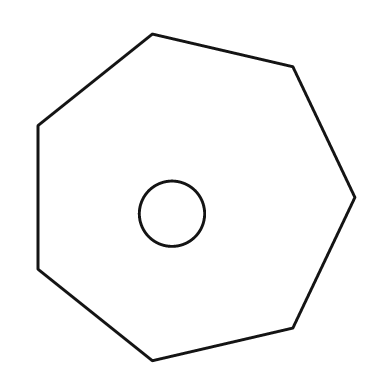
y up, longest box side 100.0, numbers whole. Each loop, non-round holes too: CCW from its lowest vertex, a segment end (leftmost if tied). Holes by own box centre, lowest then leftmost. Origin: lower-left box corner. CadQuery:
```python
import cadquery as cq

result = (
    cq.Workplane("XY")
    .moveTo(35.0, 0.0)
    .lineTo(78.0, 10.0)
    .lineTo(97.0, 50.0)
    .lineTo(78.0, 90.0)
    .lineTo(35.0, 100.0)
    .lineTo(0.0, 72.0)
    .lineTo(0.0, 28.0)
    .close()
    .moveTo(41.0, 45.0)
    .circle(10.0)
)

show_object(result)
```